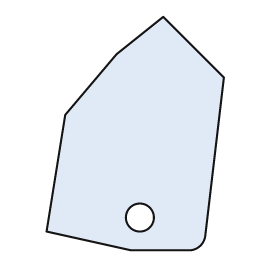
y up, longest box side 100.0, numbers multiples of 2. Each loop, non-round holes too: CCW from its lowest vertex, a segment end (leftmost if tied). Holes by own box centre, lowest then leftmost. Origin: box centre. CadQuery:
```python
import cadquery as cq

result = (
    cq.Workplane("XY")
    .moveTo(-2.0, -50.0)
    .lineTo(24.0, -50.0)
    .threePointArc((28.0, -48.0), (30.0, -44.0))
    .lineTo(38.0, 24.0)
    .lineTo(12.0, 50.0)
    .lineTo(-8.0, 34.0)
    .lineTo(-30.0, 8.0)
    .lineTo(-38.0, -42.0)
    .close()
    .moveTo(2.0, -36.0)
    .circle(6.0)
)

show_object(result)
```